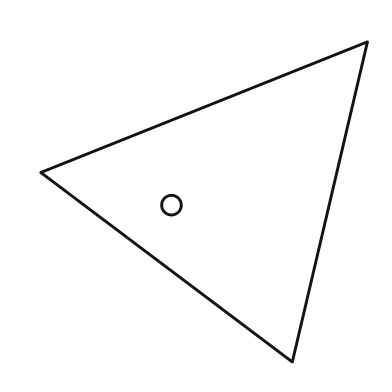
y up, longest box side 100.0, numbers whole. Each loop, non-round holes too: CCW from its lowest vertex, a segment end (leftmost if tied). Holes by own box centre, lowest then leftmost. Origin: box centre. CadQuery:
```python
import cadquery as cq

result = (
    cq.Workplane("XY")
    .moveTo(27.0, -49.0)
    .lineTo(50.0, 49.0)
    .lineTo(-50.0, 9.0)
    .close()
    .moveTo(-10.0, -1.0)
    .circle(3.0)
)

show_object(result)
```